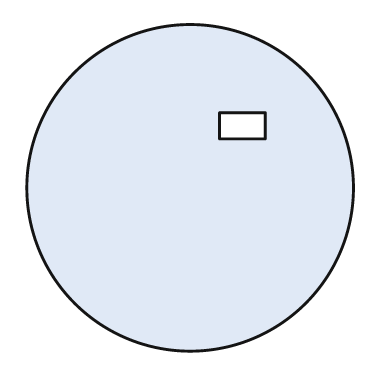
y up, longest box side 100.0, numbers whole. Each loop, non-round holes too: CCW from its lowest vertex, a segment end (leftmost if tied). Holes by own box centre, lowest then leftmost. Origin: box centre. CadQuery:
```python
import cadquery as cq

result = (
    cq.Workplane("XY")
    .moveTo(0.0, 0.0)
    .circle(50.0)
    .moveTo(9.0, 15.0)
    .lineTo(23.0, 15.0)
    .lineTo(23.0, 23.0)
    .lineTo(9.0, 23.0)
    .close()
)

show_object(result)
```